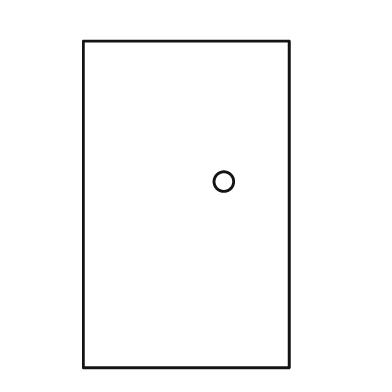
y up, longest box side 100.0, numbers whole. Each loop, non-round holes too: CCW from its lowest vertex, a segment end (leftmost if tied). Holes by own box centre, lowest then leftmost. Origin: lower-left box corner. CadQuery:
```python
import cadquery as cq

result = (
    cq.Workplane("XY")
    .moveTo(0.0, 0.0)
    .lineTo(63.0, 0.0)
    .lineTo(63.0, 100.0)
    .lineTo(0.0, 100.0)
    .close()
    .moveTo(43.0, 57.0)
    .circle(3.0)
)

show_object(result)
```